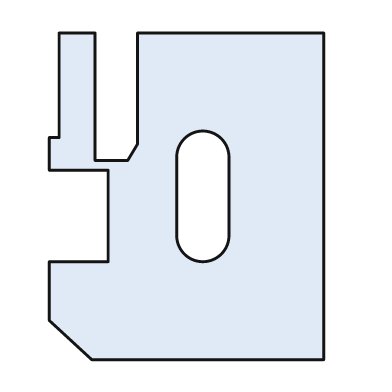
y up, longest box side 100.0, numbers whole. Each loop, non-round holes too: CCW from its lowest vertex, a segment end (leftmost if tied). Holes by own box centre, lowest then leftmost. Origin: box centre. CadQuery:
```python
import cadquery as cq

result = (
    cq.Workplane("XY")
    .moveTo(-29.0, -50.0)
    .lineTo(42.0, -50.0)
    .lineTo(42.0, 50.0)
    .lineTo(-15.0, 50.0)
    .lineTo(-15.0, 16.0)
    .lineTo(-18.0, 11.0)
    .lineTo(-28.0, 11.0)
    .lineTo(-28.0, 50.0)
    .lineTo(-39.0, 50.0)
    .lineTo(-39.0, 18.0)
    .lineTo(-42.0, 18.0)
    .lineTo(-42.0, 8.0)
    .lineTo(-24.0, 8.0)
    .lineTo(-24.0, -20.0)
    .lineTo(-42.0, -20.0)
    .lineTo(-42.0, -38.0)
    .close()
    .moveTo(-3.0, -12.0)
    .threePointArc((5.0, -20.0), (13.0, -12.0))
    .lineTo(13.0, 12.0)
    .threePointArc((5.0, 20.0), (-3.0, 12.0))
    .close()
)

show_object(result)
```